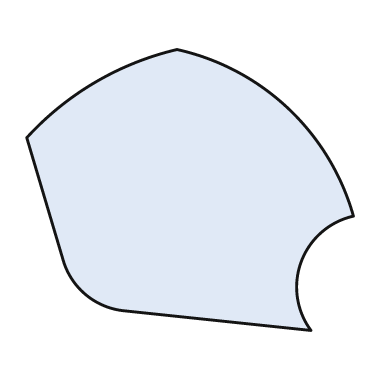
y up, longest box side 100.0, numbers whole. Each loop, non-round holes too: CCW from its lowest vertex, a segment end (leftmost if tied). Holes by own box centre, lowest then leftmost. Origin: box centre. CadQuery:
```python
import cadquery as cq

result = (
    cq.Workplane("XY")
    .moveTo(37.0, -43.0)
    .threePointArc((34.0, -22.0), (50.0, -8.0))
    .threePointArc((30.0, 25.0), (-4.0, 43.0))
    .threePointArc((-29.0, 33.0), (-50.0, 16.0))
    .lineTo(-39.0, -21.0)
    .threePointArc((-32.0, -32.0), (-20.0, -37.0))
    .close()
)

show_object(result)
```